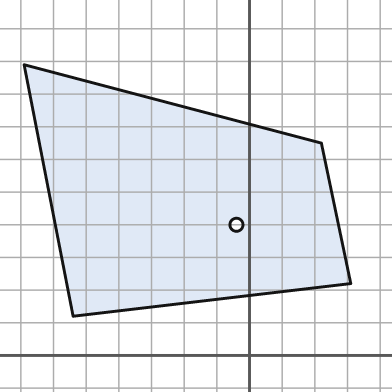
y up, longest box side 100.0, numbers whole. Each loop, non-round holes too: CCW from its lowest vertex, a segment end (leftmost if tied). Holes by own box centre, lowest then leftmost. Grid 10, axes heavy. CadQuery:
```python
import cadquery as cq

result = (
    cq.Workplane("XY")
    .moveTo(-54.0, 12.0)
    .lineTo(31.0, 22.0)
    .lineTo(22.0, 65.0)
    .lineTo(-69.0, 89.0)
    .close()
    .moveTo(-4.0, 40.0)
    .circle(2.0)
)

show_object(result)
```